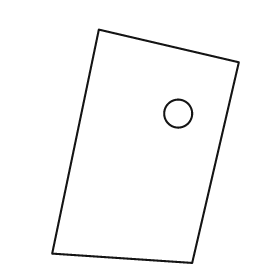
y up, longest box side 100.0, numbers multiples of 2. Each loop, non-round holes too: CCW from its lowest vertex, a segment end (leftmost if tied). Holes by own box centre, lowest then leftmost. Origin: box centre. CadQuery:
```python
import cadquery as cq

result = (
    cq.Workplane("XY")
    .moveTo(20.0, -50.0)
    .lineTo(40.0, 36.0)
    .lineTo(-20.0, 50.0)
    .lineTo(-40.0, -46.0)
    .close()
    .moveTo(14.0, 14.0)
    .circle(6.0)
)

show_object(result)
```